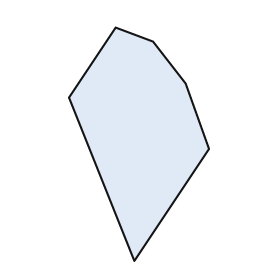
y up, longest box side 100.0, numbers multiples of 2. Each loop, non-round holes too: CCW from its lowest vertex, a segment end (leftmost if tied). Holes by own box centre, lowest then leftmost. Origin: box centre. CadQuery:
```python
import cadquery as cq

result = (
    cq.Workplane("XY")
    .moveTo(-2.0, -50.0)
    .lineTo(30.0, -2.0)
    .lineTo(20.0, 26.0)
    .lineTo(6.0, 44.0)
    .lineTo(-10.0, 50.0)
    .lineTo(-30.0, 20.0)
    .close()
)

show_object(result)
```